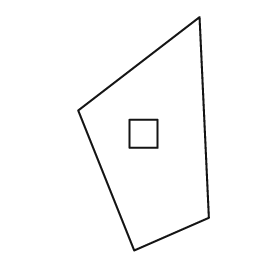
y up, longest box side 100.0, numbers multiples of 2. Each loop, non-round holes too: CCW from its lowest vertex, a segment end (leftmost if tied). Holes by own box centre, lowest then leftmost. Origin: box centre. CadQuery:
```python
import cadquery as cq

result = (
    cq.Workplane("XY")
    .moveTo(-4.0, -50.0)
    .lineTo(28.0, -36.0)
    .lineTo(24.0, 50.0)
    .lineTo(-28.0, 10.0)
    .close()
    .moveTo(-6.0, -6.0)
    .lineTo(6.0, -6.0)
    .lineTo(6.0, 6.0)
    .lineTo(-6.0, 6.0)
    .close()
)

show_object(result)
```